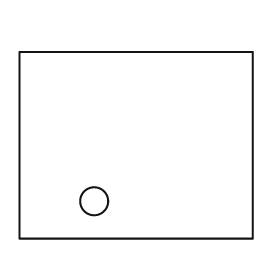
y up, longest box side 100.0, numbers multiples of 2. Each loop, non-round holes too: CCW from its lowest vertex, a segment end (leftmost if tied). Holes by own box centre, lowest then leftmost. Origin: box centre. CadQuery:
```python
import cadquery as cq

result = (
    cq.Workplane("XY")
    .moveTo(-50.0, -40.0)
    .lineTo(50.0, -40.0)
    .lineTo(50.0, 40.0)
    .lineTo(-50.0, 40.0)
    .close()
    .moveTo(-18.0, -24.0)
    .circle(6.0)
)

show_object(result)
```